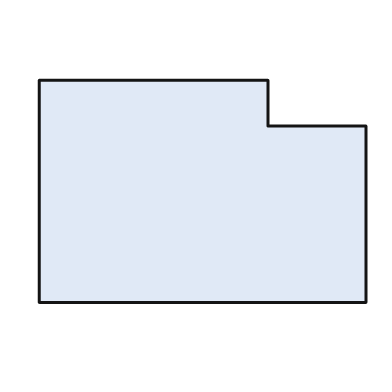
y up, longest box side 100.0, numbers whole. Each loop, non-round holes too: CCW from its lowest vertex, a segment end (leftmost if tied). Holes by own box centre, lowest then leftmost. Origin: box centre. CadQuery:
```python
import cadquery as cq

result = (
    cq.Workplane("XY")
    .moveTo(-50.0, -34.0)
    .lineTo(50.0, -34.0)
    .lineTo(50.0, 20.0)
    .lineTo(20.0, 20.0)
    .lineTo(20.0, 34.0)
    .lineTo(-50.0, 34.0)
    .close()
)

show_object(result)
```